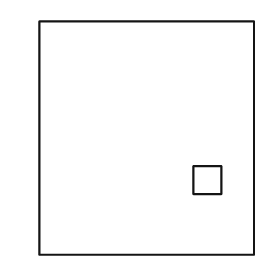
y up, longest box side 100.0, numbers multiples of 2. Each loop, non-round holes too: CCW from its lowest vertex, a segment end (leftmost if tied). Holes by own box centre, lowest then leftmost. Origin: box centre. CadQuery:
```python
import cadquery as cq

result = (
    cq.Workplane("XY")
    .moveTo(-46.0, -50.0)
    .lineTo(46.0, -50.0)
    .lineTo(46.0, 50.0)
    .lineTo(-46.0, 50.0)
    .close()
    .moveTo(20.0, -24.0)
    .lineTo(32.0, -24.0)
    .lineTo(32.0, -12.0)
    .lineTo(20.0, -12.0)
    .close()
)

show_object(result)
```